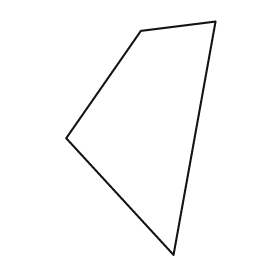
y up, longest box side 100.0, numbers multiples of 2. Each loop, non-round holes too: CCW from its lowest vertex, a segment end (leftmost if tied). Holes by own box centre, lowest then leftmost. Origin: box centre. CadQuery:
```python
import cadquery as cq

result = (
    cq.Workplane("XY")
    .moveTo(14.0, -50.0)
    .lineTo(32.0, 50.0)
    .lineTo(0.0, 46.0)
    .lineTo(-32.0, 0.0)
    .close()
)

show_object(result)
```